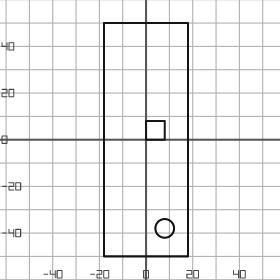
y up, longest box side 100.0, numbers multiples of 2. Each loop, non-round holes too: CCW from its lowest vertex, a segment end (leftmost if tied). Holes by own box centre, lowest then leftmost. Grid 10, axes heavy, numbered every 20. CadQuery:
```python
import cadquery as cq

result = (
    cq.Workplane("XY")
    .moveTo(-18.0, -50.0)
    .lineTo(18.0, -50.0)
    .lineTo(18.0, 50.0)
    .lineTo(-18.0, 50.0)
    .close()
    .moveTo(8.0, -38.0)
    .circle(4.0)
    .moveTo(0.0, 0.0)
    .lineTo(8.0, 0.0)
    .lineTo(8.0, 8.0)
    .lineTo(0.0, 8.0)
    .close()
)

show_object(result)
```